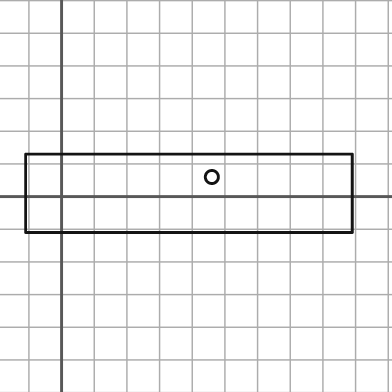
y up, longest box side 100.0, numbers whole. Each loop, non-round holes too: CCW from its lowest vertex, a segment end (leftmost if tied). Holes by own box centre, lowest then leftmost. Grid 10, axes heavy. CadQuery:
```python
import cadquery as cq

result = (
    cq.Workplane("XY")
    .moveTo(-11.0, -11.0)
    .lineTo(89.0, -11.0)
    .lineTo(89.0, 13.0)
    .lineTo(-11.0, 13.0)
    .close()
    .moveTo(46.0, 6.0)
    .circle(2.0)
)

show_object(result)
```